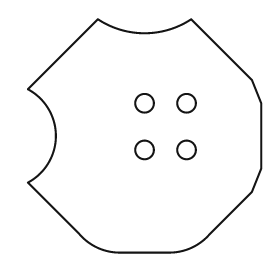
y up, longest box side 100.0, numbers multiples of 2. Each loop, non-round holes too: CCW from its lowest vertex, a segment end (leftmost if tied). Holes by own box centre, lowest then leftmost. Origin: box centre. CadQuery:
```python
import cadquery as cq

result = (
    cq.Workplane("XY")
    .moveTo(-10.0, -50.0)
    .lineTo(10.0, -50.0)
    .threePointArc((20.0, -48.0), (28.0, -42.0))
    .lineTo(46.0, -24.0)
    .lineTo(50.0, -14.0)
    .lineTo(50.0, 14.0)
    .lineTo(46.0, 24.0)
    .lineTo(20.0, 50.0)
    .threePointArc((0.0, 44.0), (-20.0, 50.0))
    .lineTo(-50.0, 20.0)
    .threePointArc((-38.0, 0.0), (-50.0, -20.0))
    .lineTo(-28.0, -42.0)
    .threePointArc((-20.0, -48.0), (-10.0, -50.0))
    .close()
    .moveTo(0.0, -6.0)
    .circle(4.0)
    .moveTo(18.0, -6.0)
    .circle(4.0)
    .moveTo(0.0, 14.0)
    .circle(4.0)
    .moveTo(18.0, 14.0)
    .circle(4.0)
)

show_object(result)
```